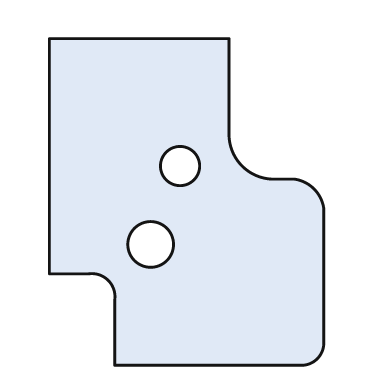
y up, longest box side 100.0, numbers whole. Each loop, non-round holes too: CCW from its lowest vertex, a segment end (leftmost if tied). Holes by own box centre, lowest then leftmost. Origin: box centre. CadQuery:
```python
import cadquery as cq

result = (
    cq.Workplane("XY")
    .moveTo(-22.0, -50.0)
    .lineTo(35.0, -50.0)
    .threePointArc((40.0, -48.0), (42.0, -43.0))
    .lineTo(42.0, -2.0)
    .threePointArc((39.0, 4.0), (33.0, 7.0))
    .lineTo(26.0, 7.0)
    .threePointArc((17.0, 11.0), (13.0, 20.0))
    .lineTo(13.0, 50.0)
    .lineTo(-42.0, 50.0)
    .lineTo(-42.0, -22.0)
    .lineTo(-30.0, -22.0)
    .threePointArc((-24.0, -24.0), (-22.0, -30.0))
    .close()
    .moveTo(-11.0, -13.0)
    .circle(7.0)
    .moveTo(-2.0, 11.0)
    .circle(6.0)
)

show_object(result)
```